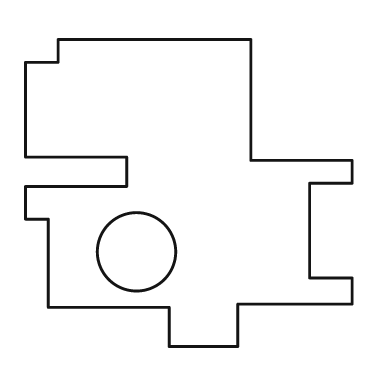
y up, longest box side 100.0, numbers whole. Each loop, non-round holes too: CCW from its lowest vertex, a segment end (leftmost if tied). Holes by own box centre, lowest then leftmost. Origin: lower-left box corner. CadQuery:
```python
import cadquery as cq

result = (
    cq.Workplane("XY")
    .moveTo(44.0, 0.0)
    .lineTo(65.0, 0.0)
    .lineTo(65.0, 13.0)
    .lineTo(100.0, 13.0)
    .lineTo(100.0, 21.0)
    .lineTo(87.0, 21.0)
    .lineTo(87.0, 50.0)
    .lineTo(100.0, 50.0)
    .lineTo(100.0, 57.0)
    .lineTo(69.0, 57.0)
    .lineTo(69.0, 94.0)
    .lineTo(10.0, 94.0)
    .lineTo(10.0, 87.0)
    .lineTo(0.0, 87.0)
    .lineTo(0.0, 58.0)
    .lineTo(31.0, 58.0)
    .lineTo(31.0, 49.0)
    .lineTo(0.0, 49.0)
    .lineTo(0.0, 39.0)
    .lineTo(7.0, 39.0)
    .lineTo(7.0, 12.0)
    .lineTo(44.0, 12.0)
    .close()
    .moveTo(34.0, 29.0)
    .circle(12.0)
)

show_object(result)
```